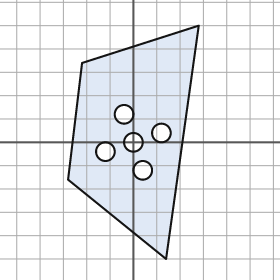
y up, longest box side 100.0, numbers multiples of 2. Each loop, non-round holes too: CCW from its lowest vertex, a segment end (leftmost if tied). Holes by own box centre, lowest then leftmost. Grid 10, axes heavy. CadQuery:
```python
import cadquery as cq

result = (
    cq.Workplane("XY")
    .moveTo(14.0, -50.0)
    .lineTo(28.0, 50.0)
    .lineTo(-22.0, 34.0)
    .lineTo(-28.0, -16.0)
    .close()
    .moveTo(4.0, -12.0)
    .circle(4.0)
    .moveTo(-12.0, -4.0)
    .circle(4.0)
    .moveTo(0.0, 0.0)
    .circle(4.0)
    .moveTo(12.0, 4.0)
    .circle(4.0)
    .moveTo(-4.0, 12.0)
    .circle(4.0)
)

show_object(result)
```